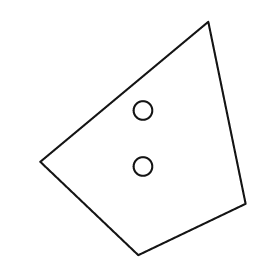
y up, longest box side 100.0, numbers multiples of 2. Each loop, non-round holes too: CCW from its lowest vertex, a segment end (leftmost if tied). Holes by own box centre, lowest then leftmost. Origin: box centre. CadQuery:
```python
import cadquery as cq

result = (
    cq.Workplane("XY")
    .moveTo(-2.0, -50.0)
    .lineTo(44.0, -28.0)
    .lineTo(28.0, 50.0)
    .lineTo(-44.0, -10.0)
    .close()
    .moveTo(0.0, -12.0)
    .circle(4.0)
    .moveTo(0.0, 12.0)
    .circle(4.0)
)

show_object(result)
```